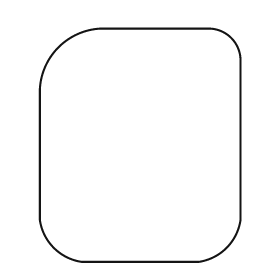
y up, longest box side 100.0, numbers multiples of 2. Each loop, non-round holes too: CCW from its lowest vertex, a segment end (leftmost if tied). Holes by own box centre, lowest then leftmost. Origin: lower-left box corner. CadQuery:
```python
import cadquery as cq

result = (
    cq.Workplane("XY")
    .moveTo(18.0, 0.0)
    .lineTo(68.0, 0.0)
    .threePointArc((80.0, 6.0), (86.0, 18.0))
    .lineTo(86.0, 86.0)
    .threePointArc((82.0, 96.0), (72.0, 100.0))
    .lineTo(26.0, 100.0)
    .threePointArc((8.0, 92.0), (0.0, 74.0))
    .lineTo(0.0, 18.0)
    .threePointArc((6.0, 6.0), (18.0, 0.0))
    .close()
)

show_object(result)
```